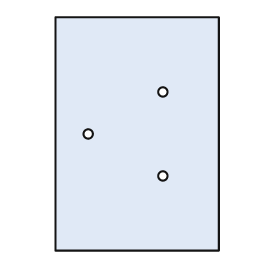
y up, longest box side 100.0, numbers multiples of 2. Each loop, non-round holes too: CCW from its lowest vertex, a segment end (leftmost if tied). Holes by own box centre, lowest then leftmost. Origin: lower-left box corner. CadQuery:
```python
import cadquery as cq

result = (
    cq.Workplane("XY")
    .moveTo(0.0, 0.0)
    .lineTo(70.0, 0.0)
    .lineTo(70.0, 100.0)
    .lineTo(0.0, 100.0)
    .close()
    .moveTo(46.0, 32.0)
    .circle(2.0)
    .moveTo(14.0, 50.0)
    .circle(2.0)
    .moveTo(46.0, 68.0)
    .circle(2.0)
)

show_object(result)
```